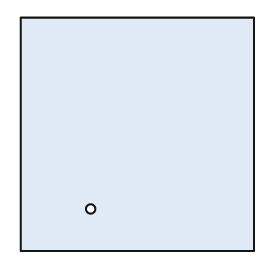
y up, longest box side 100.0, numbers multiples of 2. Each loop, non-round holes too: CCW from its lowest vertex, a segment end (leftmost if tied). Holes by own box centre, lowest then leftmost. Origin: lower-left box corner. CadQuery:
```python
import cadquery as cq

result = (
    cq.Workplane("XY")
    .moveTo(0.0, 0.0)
    .lineTo(100.0, 0.0)
    .lineTo(100.0, 100.0)
    .lineTo(0.0, 100.0)
    .close()
    .moveTo(30.0, 18.0)
    .circle(2.0)
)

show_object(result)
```